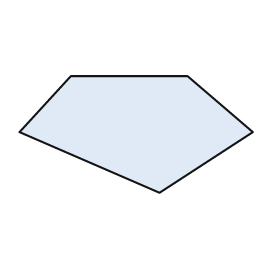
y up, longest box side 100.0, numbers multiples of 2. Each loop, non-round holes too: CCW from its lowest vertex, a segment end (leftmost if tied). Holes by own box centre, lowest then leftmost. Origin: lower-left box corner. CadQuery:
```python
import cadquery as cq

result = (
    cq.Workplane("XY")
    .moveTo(60.0, 0.0)
    .lineTo(100.0, 26.0)
    .lineTo(72.0, 50.0)
    .lineTo(22.0, 50.0)
    .lineTo(0.0, 26.0)
    .close()
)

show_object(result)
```